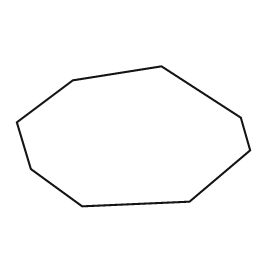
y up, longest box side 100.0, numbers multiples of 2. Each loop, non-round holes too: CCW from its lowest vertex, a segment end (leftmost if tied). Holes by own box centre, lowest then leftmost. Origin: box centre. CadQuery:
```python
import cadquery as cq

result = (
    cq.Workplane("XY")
    .moveTo(-22.0, -30.0)
    .lineTo(24.0, -28.0)
    .lineTo(50.0, -6.0)
    .lineTo(46.0, 8.0)
    .lineTo(12.0, 30.0)
    .lineTo(-26.0, 24.0)
    .lineTo(-50.0, 6.0)
    .lineTo(-44.0, -14.0)
    .close()
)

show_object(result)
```